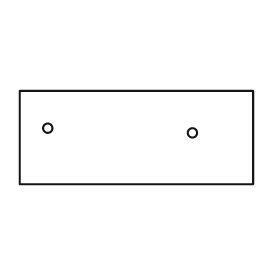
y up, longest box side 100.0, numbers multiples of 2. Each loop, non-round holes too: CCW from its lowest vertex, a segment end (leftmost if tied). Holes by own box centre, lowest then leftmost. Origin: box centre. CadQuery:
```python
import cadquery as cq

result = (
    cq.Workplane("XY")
    .moveTo(-50.0, -20.0)
    .lineTo(50.0, -20.0)
    .lineTo(50.0, 20.0)
    .lineTo(-50.0, 20.0)
    .close()
    .moveTo(24.0, 2.0)
    .circle(2.0)
    .moveTo(-38.0, 4.0)
    .circle(2.0)
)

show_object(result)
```